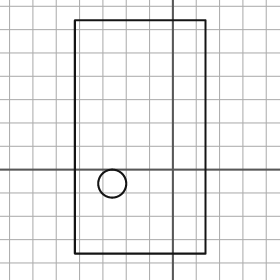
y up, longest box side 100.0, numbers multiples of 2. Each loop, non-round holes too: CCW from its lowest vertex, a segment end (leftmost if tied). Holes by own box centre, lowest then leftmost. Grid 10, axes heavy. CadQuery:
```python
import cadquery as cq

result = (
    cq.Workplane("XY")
    .moveTo(-42.0, -36.0)
    .lineTo(14.0, -36.0)
    .lineTo(14.0, 64.0)
    .lineTo(-42.0, 64.0)
    .close()
    .moveTo(-26.0, -6.0)
    .circle(6.0)
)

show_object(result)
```